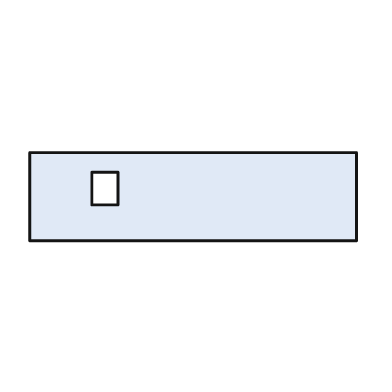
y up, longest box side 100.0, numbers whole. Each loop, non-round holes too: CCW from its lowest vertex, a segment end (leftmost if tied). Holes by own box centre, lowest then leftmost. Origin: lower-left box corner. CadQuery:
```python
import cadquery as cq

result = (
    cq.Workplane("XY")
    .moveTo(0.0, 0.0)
    .lineTo(100.0, 0.0)
    .lineTo(100.0, 27.0)
    .lineTo(0.0, 27.0)
    .close()
    .moveTo(19.0, 11.0)
    .lineTo(27.0, 11.0)
    .lineTo(27.0, 21.0)
    .lineTo(19.0, 21.0)
    .close()
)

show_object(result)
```